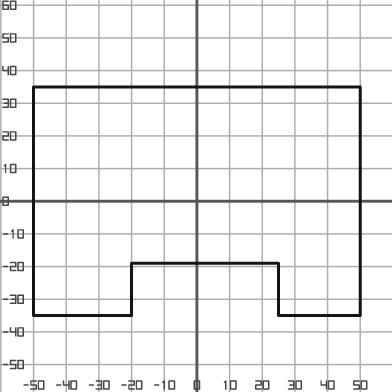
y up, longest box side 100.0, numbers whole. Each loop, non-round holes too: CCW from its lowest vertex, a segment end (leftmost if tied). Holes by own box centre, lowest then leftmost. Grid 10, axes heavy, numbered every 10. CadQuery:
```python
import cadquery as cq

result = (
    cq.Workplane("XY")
    .moveTo(-50.0, -35.0)
    .lineTo(-20.0, -35.0)
    .lineTo(-20.0, -19.0)
    .lineTo(25.0, -19.0)
    .lineTo(25.0, -35.0)
    .lineTo(50.0, -35.0)
    .lineTo(50.0, 35.0)
    .lineTo(-50.0, 35.0)
    .close()
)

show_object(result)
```